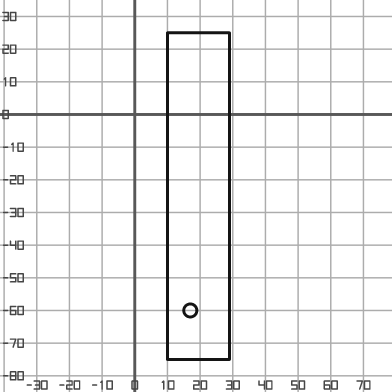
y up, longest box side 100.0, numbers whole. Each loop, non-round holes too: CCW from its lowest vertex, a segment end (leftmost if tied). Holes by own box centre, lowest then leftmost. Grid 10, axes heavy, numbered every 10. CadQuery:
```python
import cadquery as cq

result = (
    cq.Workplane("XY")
    .moveTo(10.0, -75.0)
    .lineTo(29.0, -75.0)
    .lineTo(29.0, 25.0)
    .lineTo(10.0, 25.0)
    .close()
    .moveTo(17.0, -60.0)
    .circle(2.0)
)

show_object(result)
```